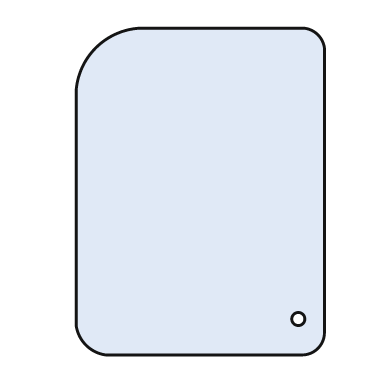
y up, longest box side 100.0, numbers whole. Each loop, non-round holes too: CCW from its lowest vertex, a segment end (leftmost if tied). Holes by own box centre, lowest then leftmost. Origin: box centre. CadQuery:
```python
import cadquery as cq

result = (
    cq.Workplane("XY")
    .moveTo(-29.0, -50.0)
    .lineTo(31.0, -50.0)
    .threePointArc((36.0, -48.0), (38.0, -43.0))
    .lineTo(38.0, 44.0)
    .threePointArc((36.0, 48.0), (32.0, 50.0))
    .lineTo(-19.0, 50.0)
    .threePointArc((-32.0, 44.0), (-38.0, 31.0))
    .lineTo(-38.0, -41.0)
    .threePointArc((-35.0, -47.0), (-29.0, -50.0))
    .close()
    .moveTo(30.0, -39.0)
    .circle(2.0)
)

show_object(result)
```